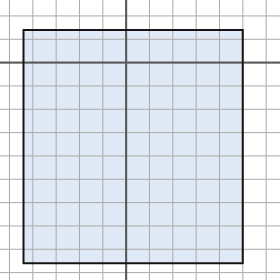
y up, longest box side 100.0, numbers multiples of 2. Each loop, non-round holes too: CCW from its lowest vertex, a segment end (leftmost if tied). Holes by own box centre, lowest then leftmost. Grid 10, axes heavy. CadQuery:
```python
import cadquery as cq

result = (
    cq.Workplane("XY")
    .moveTo(-44.0, -86.0)
    .lineTo(50.0, -86.0)
    .lineTo(50.0, 14.0)
    .lineTo(-44.0, 14.0)
    .close()
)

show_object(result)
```